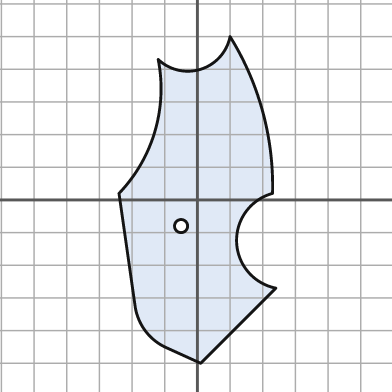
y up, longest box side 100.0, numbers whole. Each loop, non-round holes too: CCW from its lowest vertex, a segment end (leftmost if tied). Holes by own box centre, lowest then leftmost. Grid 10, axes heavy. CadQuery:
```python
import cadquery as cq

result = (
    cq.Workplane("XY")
    .moveTo(1.0, -50.0)
    .lineTo(24.0, -27.0)
    .threePointArc((12.0, -13.0), (23.0, 2.0))
    .threePointArc((20.0, 27.0), (10.0, 50.0))
    .threePointArc((1.0, 40.0), (-12.0, 43.0))
    .threePointArc((-13.0, 21.0), (-24.0, 2.0))
    .lineTo(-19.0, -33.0)
    .threePointArc((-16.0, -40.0), (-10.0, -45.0))
    .close()
    .moveTo(-5.0, -8.0)
    .circle(2.0)
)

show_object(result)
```